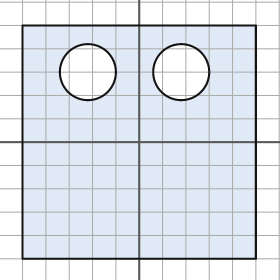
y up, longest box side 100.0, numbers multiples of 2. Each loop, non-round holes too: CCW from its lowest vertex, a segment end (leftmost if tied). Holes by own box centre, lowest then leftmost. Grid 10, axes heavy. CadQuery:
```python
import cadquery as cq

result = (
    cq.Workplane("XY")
    .moveTo(-50.0, -50.0)
    .lineTo(50.0, -50.0)
    .lineTo(50.0, 50.0)
    .lineTo(-50.0, 50.0)
    .close()
    .moveTo(-22.0, 30.0)
    .circle(12.0)
    .moveTo(18.0, 30.0)
    .circle(12.0)
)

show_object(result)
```